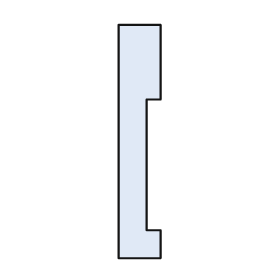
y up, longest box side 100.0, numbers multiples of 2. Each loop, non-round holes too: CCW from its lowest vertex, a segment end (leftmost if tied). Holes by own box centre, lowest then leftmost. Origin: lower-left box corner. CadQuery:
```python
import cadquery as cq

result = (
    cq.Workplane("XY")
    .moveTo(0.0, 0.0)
    .lineTo(18.0, 0.0)
    .lineTo(18.0, 12.0)
    .lineTo(12.0, 12.0)
    .lineTo(12.0, 68.0)
    .lineTo(18.0, 68.0)
    .lineTo(18.0, 100.0)
    .lineTo(0.0, 100.0)
    .close()
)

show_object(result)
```